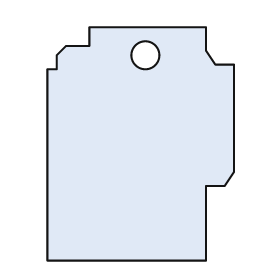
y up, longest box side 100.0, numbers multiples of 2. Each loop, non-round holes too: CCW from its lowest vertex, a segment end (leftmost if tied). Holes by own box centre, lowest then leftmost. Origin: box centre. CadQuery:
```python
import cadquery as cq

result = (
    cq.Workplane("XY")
    .moveTo(-40.0, -50.0)
    .lineTo(28.0, -50.0)
    .lineTo(28.0, -18.0)
    .lineTo(36.0, -18.0)
    .lineTo(40.0, -12.0)
    .lineTo(40.0, 34.0)
    .lineTo(32.0, 34.0)
    .lineTo(28.0, 40.0)
    .lineTo(28.0, 50.0)
    .lineTo(-22.0, 50.0)
    .lineTo(-22.0, 42.0)
    .lineTo(-32.0, 42.0)
    .lineTo(-36.0, 38.0)
    .lineTo(-36.0, 32.0)
    .lineTo(-40.0, 32.0)
    .close()
    .moveTo(2.0, 38.0)
    .circle(6.0)
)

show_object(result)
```